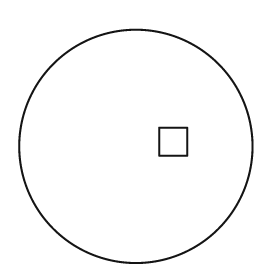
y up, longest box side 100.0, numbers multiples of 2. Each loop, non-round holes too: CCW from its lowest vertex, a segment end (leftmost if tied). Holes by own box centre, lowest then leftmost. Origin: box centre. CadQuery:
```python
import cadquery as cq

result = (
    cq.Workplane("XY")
    .moveTo(0.0, 0.0)
    .circle(50.0)
    .moveTo(10.0, -4.0)
    .lineTo(22.0, -4.0)
    .lineTo(22.0, 8.0)
    .lineTo(10.0, 8.0)
    .close()
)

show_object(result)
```